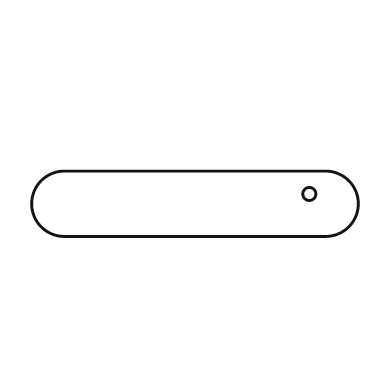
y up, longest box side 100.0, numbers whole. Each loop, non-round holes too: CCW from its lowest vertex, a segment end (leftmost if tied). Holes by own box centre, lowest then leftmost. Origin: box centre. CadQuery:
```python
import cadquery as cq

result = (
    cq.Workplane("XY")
    .moveTo(-40.0, -10.0)
    .lineTo(40.0, -10.0)
    .threePointArc((50.0, 0.0), (40.0, 10.0))
    .lineTo(-40.0, 10.0)
    .threePointArc((-50.0, 0.0), (-40.0, -10.0))
    .close()
    .moveTo(35.0, 3.0)
    .circle(2.0)
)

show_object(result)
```